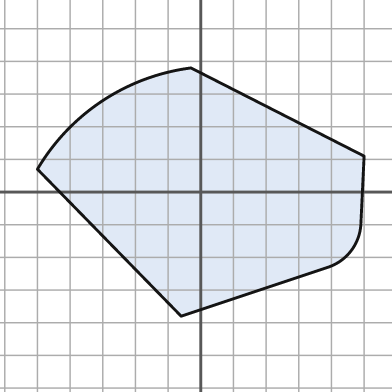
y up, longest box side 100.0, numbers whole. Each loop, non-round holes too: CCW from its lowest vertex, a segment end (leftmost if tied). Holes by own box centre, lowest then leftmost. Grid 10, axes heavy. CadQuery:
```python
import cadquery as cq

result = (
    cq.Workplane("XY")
    .moveTo(-6.0, -38.0)
    .lineTo(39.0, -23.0)
    .threePointArc((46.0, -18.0), (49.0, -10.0))
    .lineTo(50.0, 11.0)
    .lineTo(-3.0, 38.0)
    .threePointArc((-30.0, 28.0), (-50.0, 7.0))
    .close()
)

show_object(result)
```